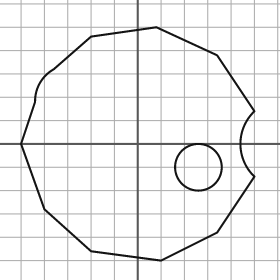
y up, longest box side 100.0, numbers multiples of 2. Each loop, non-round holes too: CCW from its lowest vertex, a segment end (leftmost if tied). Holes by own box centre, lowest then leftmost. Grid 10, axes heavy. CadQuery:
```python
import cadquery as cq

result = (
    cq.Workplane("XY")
    .moveTo(10.0, -50.0)
    .lineTo(34.0, -38.0)
    .lineTo(50.0, -14.0)
    .threePointArc((44.0, 0.0), (50.0, 14.0))
    .lineTo(34.0, 38.0)
    .lineTo(8.0, 50.0)
    .lineTo(-20.0, 46.0)
    .lineTo(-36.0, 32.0)
    .threePointArc((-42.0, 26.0), (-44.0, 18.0))
    .lineTo(-50.0, 0.0)
    .lineTo(-40.0, -28.0)
    .lineTo(-20.0, -46.0)
    .close()
    .moveTo(26.0, -10.0)
    .circle(10.0)
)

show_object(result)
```